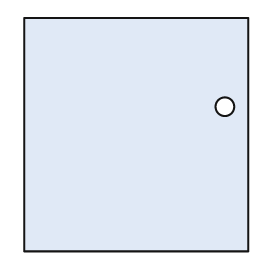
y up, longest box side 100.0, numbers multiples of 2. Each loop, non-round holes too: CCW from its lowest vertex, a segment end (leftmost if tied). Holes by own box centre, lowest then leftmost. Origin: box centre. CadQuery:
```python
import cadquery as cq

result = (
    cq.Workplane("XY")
    .moveTo(-48.0, -50.0)
    .lineTo(48.0, -50.0)
    .lineTo(48.0, 50.0)
    .lineTo(-48.0, 50.0)
    .close()
    .moveTo(38.0, 12.0)
    .circle(4.0)
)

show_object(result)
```